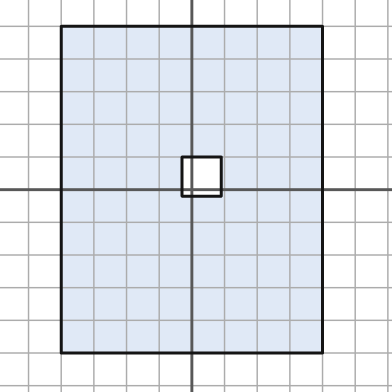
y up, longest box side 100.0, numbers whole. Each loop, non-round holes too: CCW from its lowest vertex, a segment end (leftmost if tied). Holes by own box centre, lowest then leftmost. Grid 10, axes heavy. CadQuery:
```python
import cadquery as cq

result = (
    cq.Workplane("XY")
    .moveTo(-40.0, -50.0)
    .lineTo(40.0, -50.0)
    .lineTo(40.0, 50.0)
    .lineTo(-40.0, 50.0)
    .close()
    .moveTo(-3.0, -2.0)
    .lineTo(9.0, -2.0)
    .lineTo(9.0, 10.0)
    .lineTo(-3.0, 10.0)
    .close()
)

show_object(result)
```